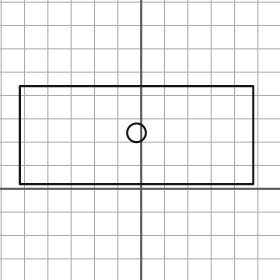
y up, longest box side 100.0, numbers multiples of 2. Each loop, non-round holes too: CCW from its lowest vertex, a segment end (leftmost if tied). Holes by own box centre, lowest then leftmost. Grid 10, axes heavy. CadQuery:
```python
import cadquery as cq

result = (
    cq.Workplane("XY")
    .moveTo(-52.0, 2.0)
    .lineTo(48.0, 2.0)
    .lineTo(48.0, 44.0)
    .lineTo(-52.0, 44.0)
    .close()
    .moveTo(-2.0, 24.0)
    .circle(4.0)
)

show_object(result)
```